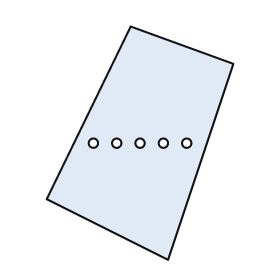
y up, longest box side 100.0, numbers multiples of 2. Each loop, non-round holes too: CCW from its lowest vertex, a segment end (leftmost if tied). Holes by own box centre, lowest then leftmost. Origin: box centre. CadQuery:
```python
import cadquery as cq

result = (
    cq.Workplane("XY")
    .moveTo(12.0, -50.0)
    .lineTo(40.0, 34.0)
    .lineTo(-4.0, 50.0)
    .lineTo(-40.0, -24.0)
    .close()
    .moveTo(-20.0, 0.0)
    .circle(2.0)
    .moveTo(-10.0, 0.0)
    .circle(2.0)
    .moveTo(0.0, 0.0)
    .circle(2.0)
    .moveTo(10.0, 0.0)
    .circle(2.0)
    .moveTo(20.0, 0.0)
    .circle(2.0)
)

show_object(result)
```